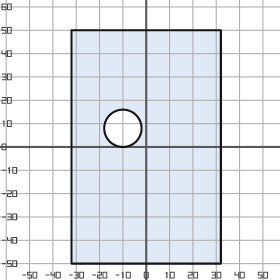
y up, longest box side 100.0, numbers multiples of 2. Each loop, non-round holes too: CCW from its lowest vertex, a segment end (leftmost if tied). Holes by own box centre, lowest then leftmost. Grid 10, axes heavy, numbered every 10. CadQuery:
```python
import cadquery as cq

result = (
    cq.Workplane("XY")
    .moveTo(-32.0, -50.0)
    .lineTo(32.0, -50.0)
    .lineTo(32.0, 50.0)
    .lineTo(-32.0, 50.0)
    .close()
    .moveTo(-10.0, 8.0)
    .circle(8.0)
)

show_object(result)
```